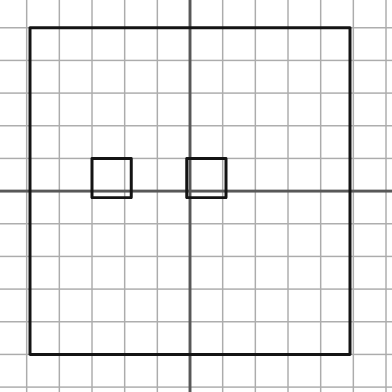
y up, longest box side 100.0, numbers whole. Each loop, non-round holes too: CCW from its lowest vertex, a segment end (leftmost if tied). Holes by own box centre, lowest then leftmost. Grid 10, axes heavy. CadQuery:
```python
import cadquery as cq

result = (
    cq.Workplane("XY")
    .moveTo(-49.0, -50.0)
    .lineTo(49.0, -50.0)
    .lineTo(49.0, 50.0)
    .lineTo(-49.0, 50.0)
    .close()
    .moveTo(-30.0, -2.0)
    .lineTo(-18.0, -2.0)
    .lineTo(-18.0, 10.0)
    .lineTo(-30.0, 10.0)
    .close()
    .moveTo(-1.0, -2.0)
    .lineTo(11.0, -2.0)
    .lineTo(11.0, 10.0)
    .lineTo(-1.0, 10.0)
    .close()
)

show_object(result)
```